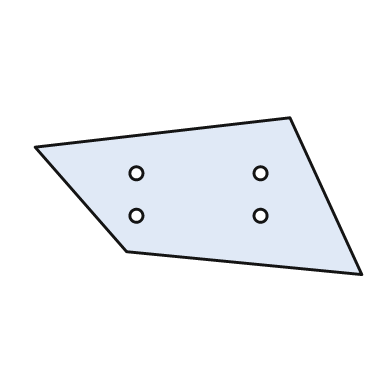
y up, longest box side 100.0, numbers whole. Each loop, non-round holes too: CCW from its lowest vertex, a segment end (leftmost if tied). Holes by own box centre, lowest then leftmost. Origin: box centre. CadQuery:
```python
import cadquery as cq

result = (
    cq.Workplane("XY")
    .moveTo(50.0, -24.0)
    .lineTo(28.0, 24.0)
    .lineTo(-50.0, 15.0)
    .lineTo(-22.0, -17.0)
    .close()
    .moveTo(-19.0, -6.0)
    .circle(2.0)
    .moveTo(19.0, -6.0)
    .circle(2.0)
    .moveTo(-19.0, 7.0)
    .circle(2.0)
    .moveTo(19.0, 7.0)
    .circle(2.0)
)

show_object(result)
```